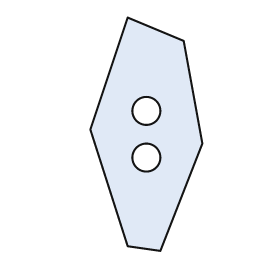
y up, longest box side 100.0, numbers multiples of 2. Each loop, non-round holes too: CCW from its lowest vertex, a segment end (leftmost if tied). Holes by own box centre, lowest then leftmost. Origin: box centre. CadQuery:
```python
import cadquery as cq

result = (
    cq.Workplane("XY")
    .moveTo(6.0, -50.0)
    .lineTo(24.0, -4.0)
    .lineTo(16.0, 40.0)
    .lineTo(-8.0, 50.0)
    .lineTo(-24.0, 2.0)
    .lineTo(-8.0, -48.0)
    .close()
    .moveTo(0.0, -10.0)
    .circle(6.0)
    .moveTo(0.0, 10.0)
    .circle(6.0)
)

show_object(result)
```